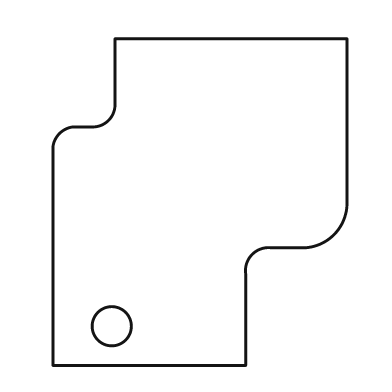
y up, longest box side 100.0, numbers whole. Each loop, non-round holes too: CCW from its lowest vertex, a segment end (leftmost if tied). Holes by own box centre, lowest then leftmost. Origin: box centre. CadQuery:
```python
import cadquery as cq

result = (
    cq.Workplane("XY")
    .moveTo(-45.0, -50.0)
    .lineTo(14.0, -50.0)
    .lineTo(14.0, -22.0)
    .threePointArc((16.0, -16.0), (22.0, -14.0))
    .lineTo(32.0, -14.0)
    .threePointArc((41.0, -10.0), (45.0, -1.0))
    .lineTo(45.0, 50.0)
    .lineTo(-26.0, 50.0)
    .lineTo(-26.0, 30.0)
    .threePointArc((-28.0, 25.0), (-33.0, 23.0))
    .lineTo(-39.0, 23.0)
    .threePointArc((-43.0, 21.0), (-45.0, 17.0))
    .close()
    .moveTo(-27.0, -38.0)
    .circle(6.0)
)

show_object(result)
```